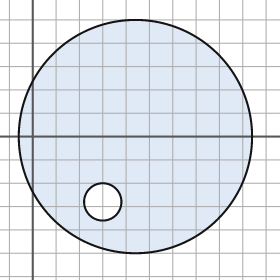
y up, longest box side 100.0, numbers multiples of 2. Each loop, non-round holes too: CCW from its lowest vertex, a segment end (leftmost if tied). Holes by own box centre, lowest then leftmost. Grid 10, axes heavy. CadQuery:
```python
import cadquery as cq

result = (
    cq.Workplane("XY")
    .moveTo(44.0, 0.0)
    .circle(50.0)
    .moveTo(30.0, -28.0)
    .circle(8.0)
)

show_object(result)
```